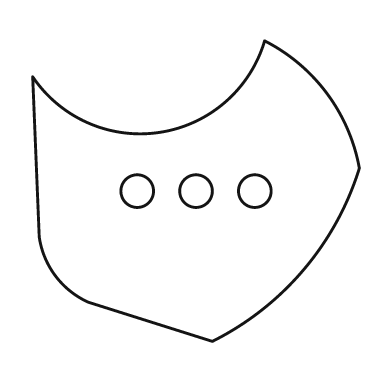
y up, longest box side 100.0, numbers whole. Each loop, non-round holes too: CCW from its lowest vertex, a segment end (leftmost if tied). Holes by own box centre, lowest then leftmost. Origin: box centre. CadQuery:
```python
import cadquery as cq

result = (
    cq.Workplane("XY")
    .moveTo(5.0, -46.0)
    .threePointArc((33.0, -24.0), (50.0, 7.0))
    .threePointArc((40.0, 30.0), (21.0, 46.0))
    .threePointArc((-11.0, 18.0), (-50.0, 35.0))
    .lineTo(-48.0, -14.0)
    .threePointArc((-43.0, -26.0), (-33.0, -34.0))
    .close()
    .moveTo(-18.0, 0.0)
    .circle(5.0)
    .moveTo(0.0, 0.0)
    .circle(5.0)
    .moveTo(18.0, 0.0)
    .circle(5.0)
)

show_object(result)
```